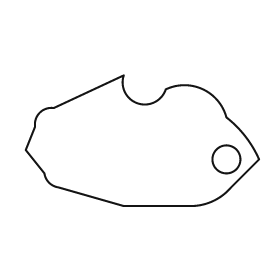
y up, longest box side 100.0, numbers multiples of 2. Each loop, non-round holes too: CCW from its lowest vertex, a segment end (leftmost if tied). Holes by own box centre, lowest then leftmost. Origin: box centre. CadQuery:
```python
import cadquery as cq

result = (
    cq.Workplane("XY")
    .moveTo(-8.0, -28.0)
    .lineTo(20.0, -28.0)
    .threePointArc((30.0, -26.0), (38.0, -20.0))
    .lineTo(50.0, -8.0)
    .threePointArc((44.0, 2.0), (36.0, 10.0))
    .threePointArc((26.0, 22.0), (10.0, 22.0))
    .threePointArc((-2.0, 16.0), (-8.0, 28.0))
    .lineTo(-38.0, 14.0)
    .threePointArc((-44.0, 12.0), (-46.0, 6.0))
    .lineTo(-50.0, -4.0)
    .lineTo(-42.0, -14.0)
    .threePointArc((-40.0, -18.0), (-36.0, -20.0))
    .close()
    .moveTo(36.0, -8.0)
    .circle(6.0)
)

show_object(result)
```